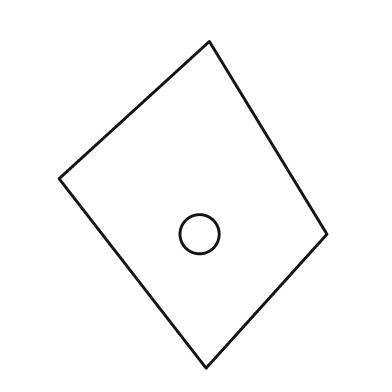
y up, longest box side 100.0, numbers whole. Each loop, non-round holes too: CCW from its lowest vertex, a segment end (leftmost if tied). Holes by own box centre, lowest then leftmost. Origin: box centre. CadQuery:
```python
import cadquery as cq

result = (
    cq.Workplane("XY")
    .moveTo(4.0, -50.0)
    .lineTo(41.0, -9.0)
    .lineTo(5.0, 50.0)
    .lineTo(-41.0, 8.0)
    .close()
    .moveTo(2.0, -9.0)
    .circle(6.0)
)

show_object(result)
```